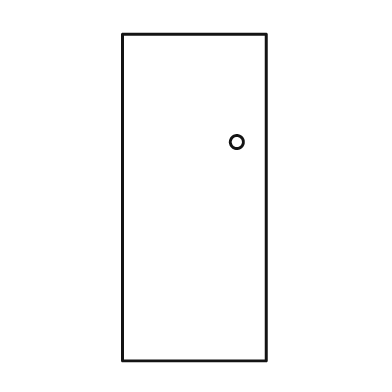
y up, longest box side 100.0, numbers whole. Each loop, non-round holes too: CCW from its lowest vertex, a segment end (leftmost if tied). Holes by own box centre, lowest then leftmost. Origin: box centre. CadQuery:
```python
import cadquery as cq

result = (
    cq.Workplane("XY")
    .moveTo(-22.0, -50.0)
    .lineTo(22.0, -50.0)
    .lineTo(22.0, 50.0)
    .lineTo(-22.0, 50.0)
    .close()
    .moveTo(13.0, 17.0)
    .circle(2.0)
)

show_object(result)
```